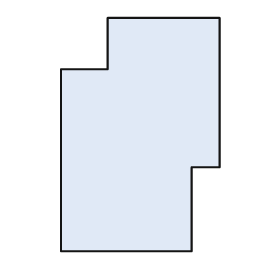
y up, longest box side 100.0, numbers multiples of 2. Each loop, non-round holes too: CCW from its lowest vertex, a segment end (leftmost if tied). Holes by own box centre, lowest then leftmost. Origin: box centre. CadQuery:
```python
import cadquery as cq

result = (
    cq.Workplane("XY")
    .moveTo(-34.0, -50.0)
    .lineTo(22.0, -50.0)
    .lineTo(22.0, -14.0)
    .lineTo(34.0, -14.0)
    .lineTo(34.0, 50.0)
    .lineTo(-14.0, 50.0)
    .lineTo(-14.0, 28.0)
    .lineTo(-34.0, 28.0)
    .close()
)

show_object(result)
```